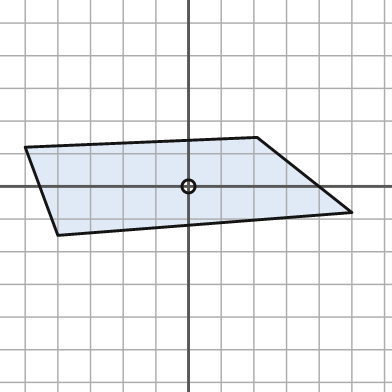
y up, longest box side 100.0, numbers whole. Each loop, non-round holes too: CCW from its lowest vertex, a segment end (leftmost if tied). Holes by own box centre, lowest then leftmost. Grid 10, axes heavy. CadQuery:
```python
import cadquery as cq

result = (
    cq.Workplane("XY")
    .moveTo(-40.0, -15.0)
    .lineTo(50.0, -8.0)
    .lineTo(21.0, 15.0)
    .lineTo(-50.0, 12.0)
    .close()
    .moveTo(0.0, 0.0)
    .circle(2.0)
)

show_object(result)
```